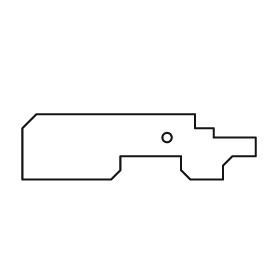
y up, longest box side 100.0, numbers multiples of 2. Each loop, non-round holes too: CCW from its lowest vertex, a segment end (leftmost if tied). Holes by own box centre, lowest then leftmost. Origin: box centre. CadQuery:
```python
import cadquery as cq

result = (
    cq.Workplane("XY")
    .moveTo(-50.0, -14.0)
    .lineTo(-12.0, -14.0)
    .lineTo(-8.0, -10.0)
    .lineTo(-8.0, -4.0)
    .lineTo(18.0, -4.0)
    .lineTo(18.0, -10.0)
    .lineTo(22.0, -14.0)
    .lineTo(36.0, -14.0)
    .lineTo(36.0, -8.0)
    .lineTo(40.0, -4.0)
    .lineTo(50.0, -4.0)
    .lineTo(50.0, 4.0)
    .lineTo(32.0, 4.0)
    .lineTo(32.0, 8.0)
    .lineTo(24.0, 8.0)
    .lineTo(24.0, 14.0)
    .lineTo(-44.0, 14.0)
    .lineTo(-50.0, 8.0)
    .close()
    .moveTo(12.0, 4.0)
    .circle(2.0)
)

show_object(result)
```